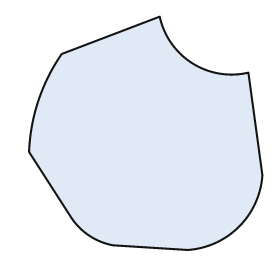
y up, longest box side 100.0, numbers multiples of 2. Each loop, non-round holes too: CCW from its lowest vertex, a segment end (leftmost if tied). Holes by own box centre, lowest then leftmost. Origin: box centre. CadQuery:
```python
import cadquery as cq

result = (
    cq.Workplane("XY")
    .moveTo(18.0, -50.0)
    .threePointArc((40.0, -40.0), (50.0, -18.0))
    .lineTo(44.0, 26.0)
    .threePointArc((20.0, 30.0), (6.0, 50.0))
    .lineTo(-36.0, 34.0)
    .threePointArc((-46.0, 14.0), (-50.0, -8.0))
    .lineTo(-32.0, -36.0)
    .threePointArc((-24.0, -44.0), (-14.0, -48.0))
    .close()
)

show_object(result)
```